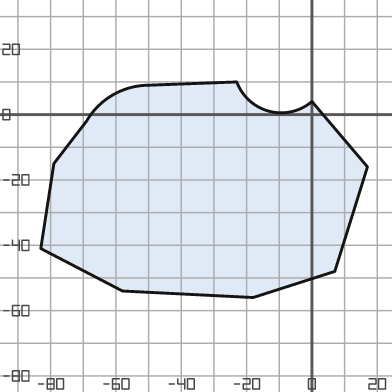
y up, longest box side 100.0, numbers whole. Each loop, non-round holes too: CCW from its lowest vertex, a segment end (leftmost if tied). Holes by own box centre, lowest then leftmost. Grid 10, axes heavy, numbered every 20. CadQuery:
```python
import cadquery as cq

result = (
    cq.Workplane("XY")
    .moveTo(-18.0, -56.0)
    .lineTo(7.0, -48.0)
    .lineTo(17.0, -16.0)
    .lineTo(0.0, 4.0)
    .threePointArc((-13.0, 1.0), (-23.0, 10.0))
    .lineTo(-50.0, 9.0)
    .threePointArc((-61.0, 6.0), (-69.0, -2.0))
    .lineTo(-79.0, -15.0)
    .lineTo(-83.0, -41.0)
    .lineTo(-58.0, -54.0)
    .close()
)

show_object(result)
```